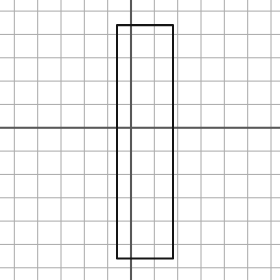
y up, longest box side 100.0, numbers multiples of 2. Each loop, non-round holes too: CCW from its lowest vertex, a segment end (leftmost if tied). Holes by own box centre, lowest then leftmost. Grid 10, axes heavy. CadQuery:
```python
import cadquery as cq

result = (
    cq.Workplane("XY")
    .moveTo(-6.0, -56.0)
    .lineTo(18.0, -56.0)
    .lineTo(18.0, 44.0)
    .lineTo(-6.0, 44.0)
    .close()
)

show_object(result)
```